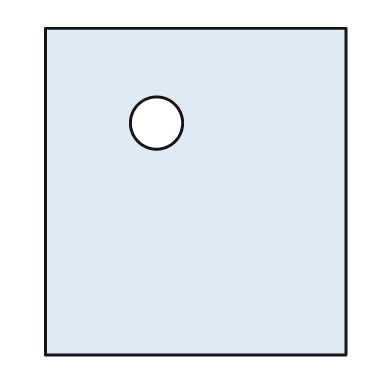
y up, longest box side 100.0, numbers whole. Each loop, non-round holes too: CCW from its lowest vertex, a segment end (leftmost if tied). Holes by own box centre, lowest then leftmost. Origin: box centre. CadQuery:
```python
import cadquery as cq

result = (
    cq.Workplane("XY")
    .moveTo(-46.0, -50.0)
    .lineTo(46.0, -50.0)
    .lineTo(46.0, 50.0)
    .lineTo(-46.0, 50.0)
    .close()
    .moveTo(-12.0, 21.0)
    .circle(8.0)
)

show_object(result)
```